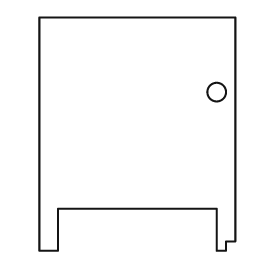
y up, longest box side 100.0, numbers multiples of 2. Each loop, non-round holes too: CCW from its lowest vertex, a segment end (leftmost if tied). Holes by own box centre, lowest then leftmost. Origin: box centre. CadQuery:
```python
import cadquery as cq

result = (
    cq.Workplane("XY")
    .moveTo(-42.0, -50.0)
    .lineTo(-34.0, -50.0)
    .lineTo(-34.0, -32.0)
    .lineTo(34.0, -32.0)
    .lineTo(34.0, -50.0)
    .lineTo(38.0, -50.0)
    .lineTo(38.0, -46.0)
    .lineTo(42.0, -46.0)
    .lineTo(42.0, 50.0)
    .lineTo(-42.0, 50.0)
    .close()
    .moveTo(34.0, 18.0)
    .circle(4.0)
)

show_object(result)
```